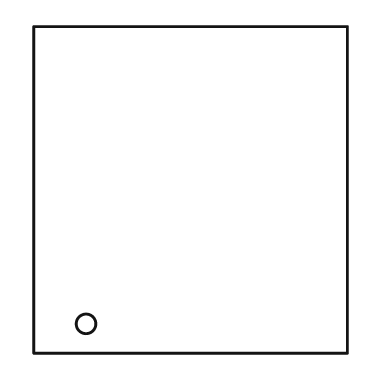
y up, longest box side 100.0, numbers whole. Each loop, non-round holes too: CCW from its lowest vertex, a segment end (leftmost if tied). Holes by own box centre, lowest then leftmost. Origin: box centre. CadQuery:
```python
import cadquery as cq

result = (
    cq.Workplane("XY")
    .moveTo(-48.0, -50.0)
    .lineTo(48.0, -50.0)
    .lineTo(48.0, 50.0)
    .lineTo(-48.0, 50.0)
    .close()
    .moveTo(-32.0, -41.0)
    .circle(3.0)
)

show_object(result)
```